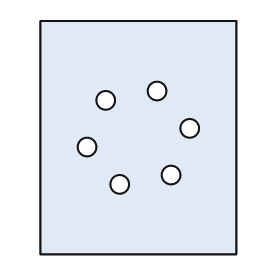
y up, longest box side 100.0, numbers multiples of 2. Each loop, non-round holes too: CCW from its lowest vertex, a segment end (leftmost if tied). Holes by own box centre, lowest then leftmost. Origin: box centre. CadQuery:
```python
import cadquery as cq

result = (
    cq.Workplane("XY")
    .moveTo(-42.0, -50.0)
    .lineTo(42.0, -50.0)
    .lineTo(42.0, 50.0)
    .lineTo(-42.0, 50.0)
    .close()
    .moveTo(-8.0, -20.0)
    .circle(4.0)
    .moveTo(14.0, -16.0)
    .circle(4.0)
    .moveTo(-22.0, -4.0)
    .circle(4.0)
    .moveTo(22.0, 4.0)
    .circle(4.0)
    .moveTo(-14.0, 16.0)
    .circle(4.0)
    .moveTo(8.0, 20.0)
    .circle(4.0)
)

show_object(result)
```